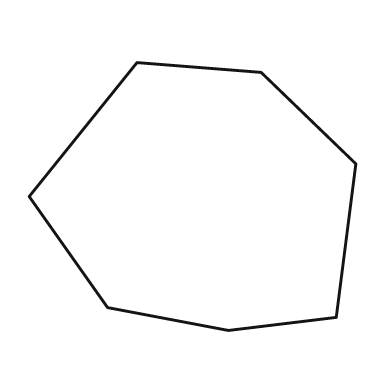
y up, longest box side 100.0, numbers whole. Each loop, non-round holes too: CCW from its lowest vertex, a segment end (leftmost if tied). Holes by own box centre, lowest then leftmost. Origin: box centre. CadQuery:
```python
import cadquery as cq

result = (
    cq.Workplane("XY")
    .moveTo(11.0, -41.0)
    .lineTo(44.0, -37.0)
    .lineTo(50.0, 10.0)
    .lineTo(21.0, 38.0)
    .lineTo(-17.0, 41.0)
    .lineTo(-50.0, 0.0)
    .lineTo(-26.0, -34.0)
    .close()
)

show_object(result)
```